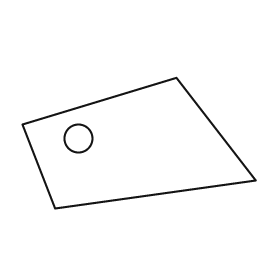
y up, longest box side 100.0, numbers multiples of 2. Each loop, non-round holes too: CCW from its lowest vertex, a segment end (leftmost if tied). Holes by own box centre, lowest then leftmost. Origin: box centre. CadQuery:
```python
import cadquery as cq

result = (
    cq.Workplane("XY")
    .moveTo(-36.0, -28.0)
    .lineTo(50.0, -16.0)
    .lineTo(16.0, 28.0)
    .lineTo(-50.0, 8.0)
    .close()
    .moveTo(-26.0, 2.0)
    .circle(6.0)
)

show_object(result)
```